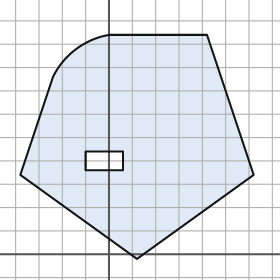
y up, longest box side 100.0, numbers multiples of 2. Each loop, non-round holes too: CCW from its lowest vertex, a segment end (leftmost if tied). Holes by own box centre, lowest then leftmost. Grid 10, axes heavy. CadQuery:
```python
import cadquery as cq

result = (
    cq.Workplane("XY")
    .moveTo(12.0, -2.0)
    .lineTo(62.0, 34.0)
    .lineTo(42.0, 94.0)
    .lineTo(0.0, 94.0)
    .threePointArc((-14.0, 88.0), (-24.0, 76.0))
    .lineTo(-38.0, 34.0)
    .close()
    .moveTo(-10.0, 36.0)
    .lineTo(6.0, 36.0)
    .lineTo(6.0, 44.0)
    .lineTo(-10.0, 44.0)
    .close()
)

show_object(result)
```